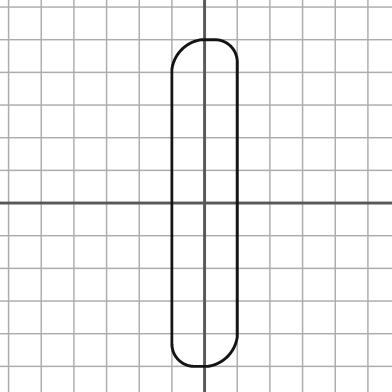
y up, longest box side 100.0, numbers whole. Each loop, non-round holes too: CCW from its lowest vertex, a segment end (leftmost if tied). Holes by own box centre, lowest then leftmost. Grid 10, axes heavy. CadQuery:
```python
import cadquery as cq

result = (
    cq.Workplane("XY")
    .moveTo(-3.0, -50.0)
    .lineTo(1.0, -50.0)
    .threePointArc((7.0, -47.0), (10.0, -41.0))
    .lineTo(10.0, 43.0)
    .threePointArc((8.0, 48.0), (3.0, 50.0))
    .lineTo(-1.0, 50.0)
    .threePointArc((-7.0, 47.0), (-10.0, 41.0))
    .lineTo(-10.0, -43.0)
    .threePointArc((-8.0, -48.0), (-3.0, -50.0))
    .close()
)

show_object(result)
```